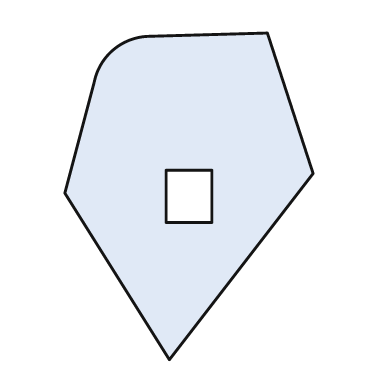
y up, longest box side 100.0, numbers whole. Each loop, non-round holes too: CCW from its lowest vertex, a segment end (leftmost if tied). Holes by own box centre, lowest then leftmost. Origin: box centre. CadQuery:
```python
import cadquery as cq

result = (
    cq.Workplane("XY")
    .moveTo(-6.0, -50.0)
    .lineTo(38.0, 7.0)
    .lineTo(24.0, 50.0)
    .lineTo(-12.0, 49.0)
    .threePointArc((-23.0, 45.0), (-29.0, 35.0))
    .lineTo(-38.0, 1.0)
    .close()
    .moveTo(-7.0, -8.0)
    .lineTo(7.0, -8.0)
    .lineTo(7.0, 8.0)
    .lineTo(-7.0, 8.0)
    .close()
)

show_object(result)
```